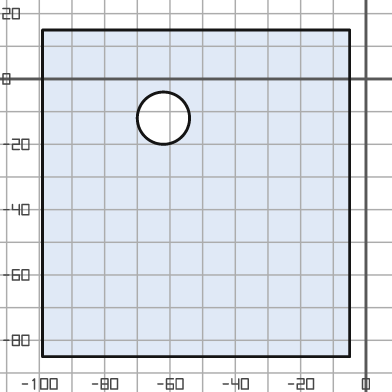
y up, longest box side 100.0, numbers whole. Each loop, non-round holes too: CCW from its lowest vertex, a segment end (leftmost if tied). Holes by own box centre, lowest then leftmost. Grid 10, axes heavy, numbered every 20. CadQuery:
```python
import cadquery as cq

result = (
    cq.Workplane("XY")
    .moveTo(-99.0, -85.0)
    .lineTo(-5.0, -85.0)
    .lineTo(-5.0, 15.0)
    .lineTo(-99.0, 15.0)
    .close()
    .moveTo(-62.0, -12.0)
    .circle(8.0)
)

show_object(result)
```